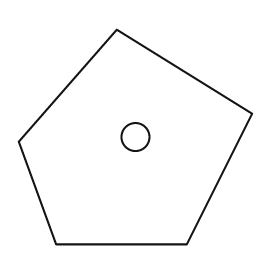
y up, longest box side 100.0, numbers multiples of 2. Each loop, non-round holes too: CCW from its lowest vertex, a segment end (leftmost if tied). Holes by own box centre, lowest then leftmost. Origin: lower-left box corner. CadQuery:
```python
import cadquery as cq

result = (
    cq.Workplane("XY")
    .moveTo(16.0, 0.0)
    .lineTo(72.0, 0.0)
    .lineTo(100.0, 56.0)
    .lineTo(42.0, 92.0)
    .lineTo(0.0, 44.0)
    .close()
    .moveTo(50.0, 46.0)
    .circle(6.0)
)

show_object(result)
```